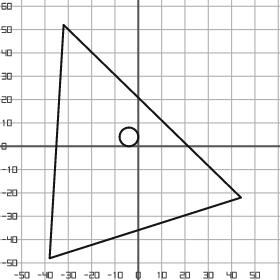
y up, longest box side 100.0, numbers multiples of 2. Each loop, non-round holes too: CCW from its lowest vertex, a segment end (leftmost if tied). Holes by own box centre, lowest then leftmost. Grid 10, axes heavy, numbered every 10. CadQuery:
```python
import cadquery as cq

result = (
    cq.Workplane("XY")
    .moveTo(-38.0, -48.0)
    .lineTo(44.0, -22.0)
    .lineTo(-32.0, 52.0)
    .close()
    .moveTo(-4.0, 4.0)
    .circle(4.0)
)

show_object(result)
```